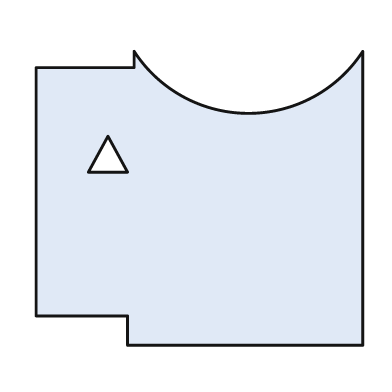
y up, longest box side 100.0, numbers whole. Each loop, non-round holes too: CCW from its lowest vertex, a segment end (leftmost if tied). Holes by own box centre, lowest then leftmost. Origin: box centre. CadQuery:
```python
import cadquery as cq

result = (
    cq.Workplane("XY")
    .moveTo(-22.0, -45.0)
    .lineTo(50.0, -45.0)
    .lineTo(50.0, 45.0)
    .threePointArc((15.0, 26.0), (-20.0, 45.0))
    .lineTo(-20.0, 40.0)
    .lineTo(-50.0, 40.0)
    .lineTo(-50.0, -36.0)
    .lineTo(-22.0, -36.0)
    .close()
    .moveTo(-34.0, 8.0)
    .lineTo(-22.0, 8.0)
    .lineTo(-28.0, 19.0)
    .close()
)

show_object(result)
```